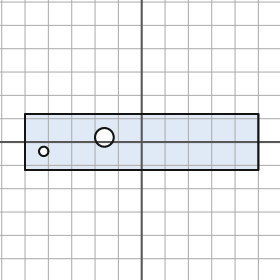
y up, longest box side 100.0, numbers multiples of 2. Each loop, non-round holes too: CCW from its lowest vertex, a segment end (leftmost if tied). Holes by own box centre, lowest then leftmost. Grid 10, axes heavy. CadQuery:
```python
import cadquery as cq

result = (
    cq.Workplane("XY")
    .moveTo(-50.0, -12.0)
    .lineTo(50.0, -12.0)
    .lineTo(50.0, 12.0)
    .lineTo(-50.0, 12.0)
    .close()
    .moveTo(-42.0, -4.0)
    .circle(2.0)
    .moveTo(-16.0, 2.0)
    .circle(4.0)
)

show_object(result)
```